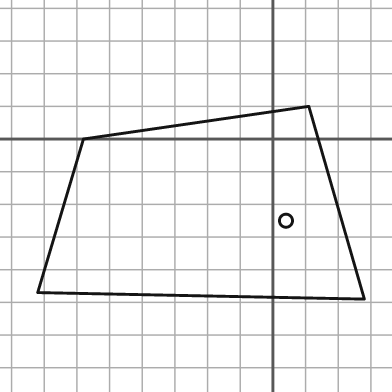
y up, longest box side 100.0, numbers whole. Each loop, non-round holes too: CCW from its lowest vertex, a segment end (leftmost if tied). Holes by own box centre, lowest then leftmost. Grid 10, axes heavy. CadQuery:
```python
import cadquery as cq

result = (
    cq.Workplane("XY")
    .moveTo(28.0, -49.0)
    .lineTo(11.0, 10.0)
    .lineTo(-58.0, 0.0)
    .lineTo(-72.0, -47.0)
    .close()
    .moveTo(4.0, -25.0)
    .circle(2.0)
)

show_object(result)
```